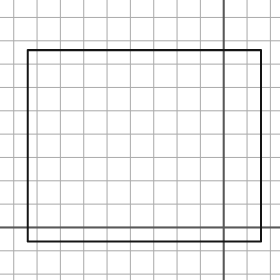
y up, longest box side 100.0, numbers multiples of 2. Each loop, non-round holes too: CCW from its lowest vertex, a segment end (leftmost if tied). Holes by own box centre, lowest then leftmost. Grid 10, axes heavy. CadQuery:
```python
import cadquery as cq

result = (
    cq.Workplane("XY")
    .moveTo(-84.0, -6.0)
    .lineTo(16.0, -6.0)
    .lineTo(16.0, 76.0)
    .lineTo(-84.0, 76.0)
    .close()
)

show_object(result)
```